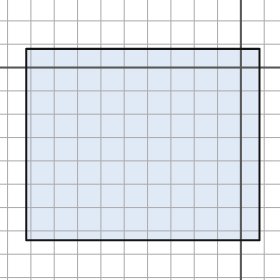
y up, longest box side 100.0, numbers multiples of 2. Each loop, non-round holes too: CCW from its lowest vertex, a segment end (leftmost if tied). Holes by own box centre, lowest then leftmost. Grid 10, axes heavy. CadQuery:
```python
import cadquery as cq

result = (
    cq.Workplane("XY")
    .moveTo(-92.0, -74.0)
    .lineTo(8.0, -74.0)
    .lineTo(8.0, 8.0)
    .lineTo(-92.0, 8.0)
    .close()
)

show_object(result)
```